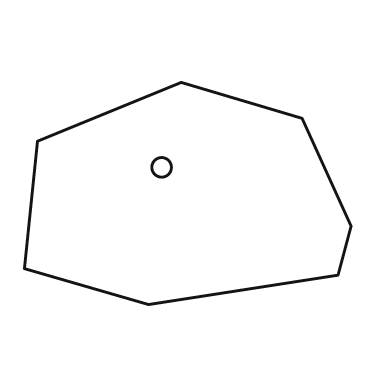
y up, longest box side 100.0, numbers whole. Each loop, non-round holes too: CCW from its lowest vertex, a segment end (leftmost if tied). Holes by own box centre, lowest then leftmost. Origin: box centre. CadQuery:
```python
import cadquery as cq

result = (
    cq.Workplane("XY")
    .moveTo(-12.0, -34.0)
    .lineTo(46.0, -25.0)
    .lineTo(50.0, -10.0)
    .lineTo(35.0, 23.0)
    .lineTo(-2.0, 34.0)
    .lineTo(-46.0, 16.0)
    .lineTo(-50.0, -23.0)
    .close()
    .moveTo(-8.0, 8.0)
    .circle(3.0)
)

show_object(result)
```